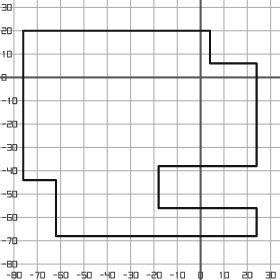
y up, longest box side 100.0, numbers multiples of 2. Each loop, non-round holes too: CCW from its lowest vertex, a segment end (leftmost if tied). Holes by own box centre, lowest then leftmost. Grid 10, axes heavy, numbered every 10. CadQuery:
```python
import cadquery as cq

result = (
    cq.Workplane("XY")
    .moveTo(-62.0, -68.0)
    .lineTo(24.0, -68.0)
    .lineTo(24.0, -56.0)
    .lineTo(-18.0, -56.0)
    .lineTo(-18.0, -38.0)
    .lineTo(24.0, -38.0)
    .lineTo(24.0, 6.0)
    .lineTo(4.0, 6.0)
    .lineTo(4.0, 20.0)
    .lineTo(-76.0, 20.0)
    .lineTo(-76.0, -44.0)
    .lineTo(-62.0, -44.0)
    .close()
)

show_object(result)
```